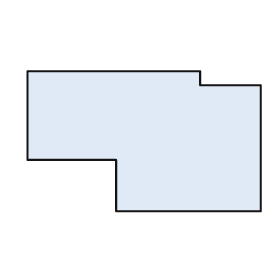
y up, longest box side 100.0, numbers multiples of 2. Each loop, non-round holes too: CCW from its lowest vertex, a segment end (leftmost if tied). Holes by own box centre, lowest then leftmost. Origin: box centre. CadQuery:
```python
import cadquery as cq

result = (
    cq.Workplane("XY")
    .moveTo(-12.0, -30.0)
    .lineTo(50.0, -30.0)
    .lineTo(50.0, 24.0)
    .lineTo(24.0, 24.0)
    .lineTo(24.0, 30.0)
    .lineTo(-50.0, 30.0)
    .lineTo(-50.0, -8.0)
    .lineTo(-12.0, -8.0)
    .close()
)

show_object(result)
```